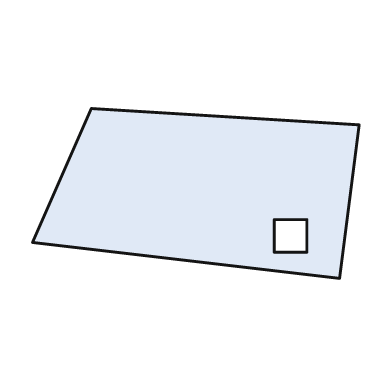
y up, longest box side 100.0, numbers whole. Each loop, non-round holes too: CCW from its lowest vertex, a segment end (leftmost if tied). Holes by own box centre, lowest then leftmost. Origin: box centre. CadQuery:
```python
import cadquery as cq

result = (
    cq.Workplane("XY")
    .moveTo(44.0, -26.0)
    .lineTo(50.0, 21.0)
    .lineTo(-32.0, 26.0)
    .lineTo(-50.0, -15.0)
    .close()
    .moveTo(24.0, -18.0)
    .lineTo(34.0, -18.0)
    .lineTo(34.0, -8.0)
    .lineTo(24.0, -8.0)
    .close()
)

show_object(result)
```